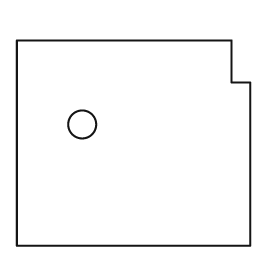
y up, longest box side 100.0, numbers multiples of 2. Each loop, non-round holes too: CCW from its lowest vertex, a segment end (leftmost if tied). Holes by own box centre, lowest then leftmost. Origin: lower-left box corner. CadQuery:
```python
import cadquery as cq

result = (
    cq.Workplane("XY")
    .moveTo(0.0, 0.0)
    .lineTo(100.0, 0.0)
    .lineTo(100.0, 70.0)
    .lineTo(92.0, 70.0)
    .lineTo(92.0, 88.0)
    .lineTo(0.0, 88.0)
    .close()
    .moveTo(28.0, 52.0)
    .circle(6.0)
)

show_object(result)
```